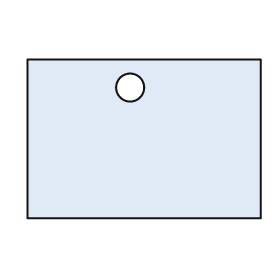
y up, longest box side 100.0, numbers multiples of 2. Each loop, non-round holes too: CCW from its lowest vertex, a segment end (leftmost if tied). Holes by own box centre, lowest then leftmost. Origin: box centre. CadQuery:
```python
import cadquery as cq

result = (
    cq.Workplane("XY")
    .moveTo(-50.0, -34.0)
    .lineTo(50.0, -34.0)
    .lineTo(50.0, 34.0)
    .lineTo(-50.0, 34.0)
    .close()
    .moveTo(-6.0, 22.0)
    .circle(6.0)
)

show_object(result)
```